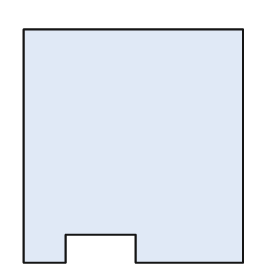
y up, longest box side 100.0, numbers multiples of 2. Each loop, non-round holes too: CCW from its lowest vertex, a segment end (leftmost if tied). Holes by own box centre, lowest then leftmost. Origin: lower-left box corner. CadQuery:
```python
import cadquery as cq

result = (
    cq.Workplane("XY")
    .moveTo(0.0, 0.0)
    .lineTo(18.0, 0.0)
    .lineTo(18.0, 12.0)
    .lineTo(48.0, 12.0)
    .lineTo(48.0, 0.0)
    .lineTo(94.0, 0.0)
    .lineTo(94.0, 100.0)
    .lineTo(0.0, 100.0)
    .close()
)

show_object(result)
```